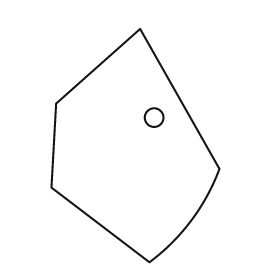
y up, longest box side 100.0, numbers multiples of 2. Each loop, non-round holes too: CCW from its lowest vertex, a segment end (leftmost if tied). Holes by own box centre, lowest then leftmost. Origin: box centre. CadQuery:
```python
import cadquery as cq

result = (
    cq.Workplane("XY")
    .moveTo(6.0, -50.0)
    .threePointArc((24.0, -32.0), (36.0, -10.0))
    .lineTo(2.0, 50.0)
    .lineTo(-34.0, 18.0)
    .lineTo(-36.0, -18.0)
    .close()
    .moveTo(8.0, 12.0)
    .circle(4.0)
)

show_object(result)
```